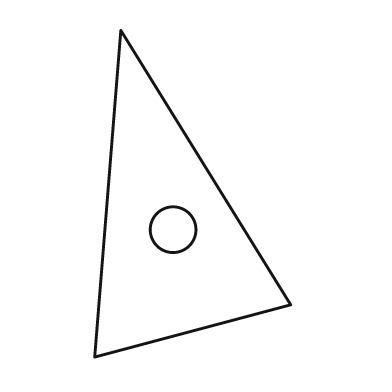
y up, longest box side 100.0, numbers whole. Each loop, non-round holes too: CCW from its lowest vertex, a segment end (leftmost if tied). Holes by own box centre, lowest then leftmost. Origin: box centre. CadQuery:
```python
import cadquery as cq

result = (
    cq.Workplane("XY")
    .moveTo(-30.0, -50.0)
    .lineTo(30.0, -34.0)
    .lineTo(-22.0, 50.0)
    .close()
    .moveTo(-6.0, -11.0)
    .circle(7.0)
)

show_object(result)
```